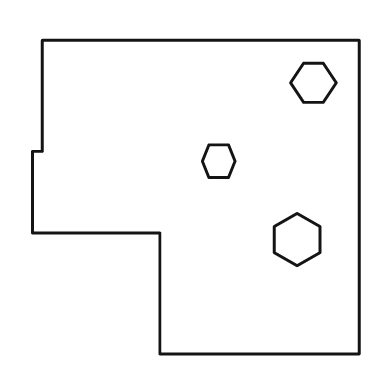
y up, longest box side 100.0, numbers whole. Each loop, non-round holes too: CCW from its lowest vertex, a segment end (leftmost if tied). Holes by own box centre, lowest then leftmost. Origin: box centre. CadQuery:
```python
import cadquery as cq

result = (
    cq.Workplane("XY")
    .moveTo(-11.0, -48.0)
    .lineTo(50.0, -48.0)
    .lineTo(50.0, 48.0)
    .lineTo(-47.0, 48.0)
    .lineTo(-47.0, 14.0)
    .lineTo(-50.0, 14.0)
    .lineTo(-50.0, -11.0)
    .lineTo(-11.0, -11.0)
    .close()
    .moveTo(31.0, -21.0)
    .lineTo(38.0, -17.0)
    .lineTo(38.0, -9.0)
    .lineTo(31.0, -5.0)
    .lineTo(24.0, -9.0)
    .lineTo(24.0, -17.0)
    .close()
    .moveTo(4.0, 6.0)
    .lineTo(10.0, 6.0)
    .lineTo(12.0, 11.0)
    .lineTo(10.0, 16.0)
    .lineTo(4.0, 16.0)
    .lineTo(2.0, 11.0)
    .close()
    .moveTo(33.0, 29.0)
    .lineTo(39.0, 29.0)
    .lineTo(43.0, 35.0)
    .lineTo(39.0, 41.0)
    .lineTo(33.0, 41.0)
    .lineTo(29.0, 35.0)
    .close()
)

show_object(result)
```